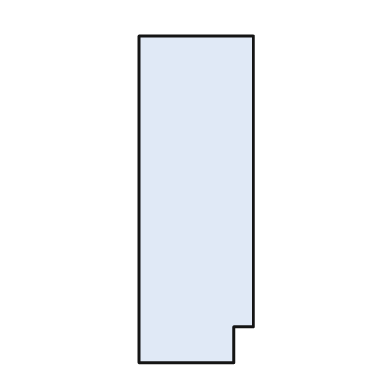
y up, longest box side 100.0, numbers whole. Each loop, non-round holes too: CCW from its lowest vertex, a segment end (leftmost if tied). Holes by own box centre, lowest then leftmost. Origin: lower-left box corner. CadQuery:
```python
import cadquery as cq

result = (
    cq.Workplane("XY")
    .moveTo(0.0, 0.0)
    .lineTo(29.0, 0.0)
    .lineTo(29.0, 11.0)
    .lineTo(35.0, 11.0)
    .lineTo(35.0, 100.0)
    .lineTo(0.0, 100.0)
    .close()
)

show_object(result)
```